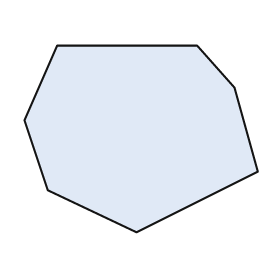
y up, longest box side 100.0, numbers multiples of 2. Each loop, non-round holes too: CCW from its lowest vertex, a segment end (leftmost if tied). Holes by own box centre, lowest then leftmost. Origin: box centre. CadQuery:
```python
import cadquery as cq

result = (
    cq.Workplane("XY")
    .moveTo(-2.0, -40.0)
    .lineTo(50.0, -14.0)
    .lineTo(40.0, 22.0)
    .lineTo(24.0, 40.0)
    .lineTo(-36.0, 40.0)
    .lineTo(-50.0, 8.0)
    .lineTo(-40.0, -22.0)
    .close()
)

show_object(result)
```